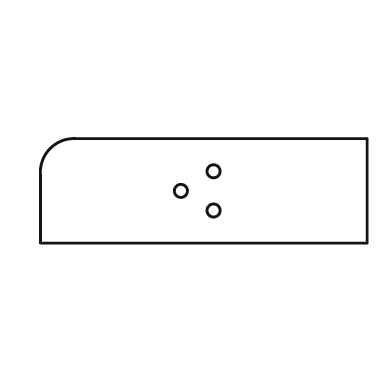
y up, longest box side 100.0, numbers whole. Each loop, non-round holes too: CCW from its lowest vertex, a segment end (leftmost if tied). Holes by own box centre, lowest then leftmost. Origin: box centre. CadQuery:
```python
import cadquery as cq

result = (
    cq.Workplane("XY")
    .moveTo(-50.0, -16.0)
    .lineTo(50.0, -16.0)
    .lineTo(50.0, 16.0)
    .lineTo(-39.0, 16.0)
    .threePointArc((-47.0, 13.0), (-50.0, 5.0))
    .close()
    .moveTo(3.0, -6.0)
    .circle(2.0)
    .moveTo(-7.0, 0.0)
    .circle(2.0)
    .moveTo(3.0, 6.0)
    .circle(2.0)
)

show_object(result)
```